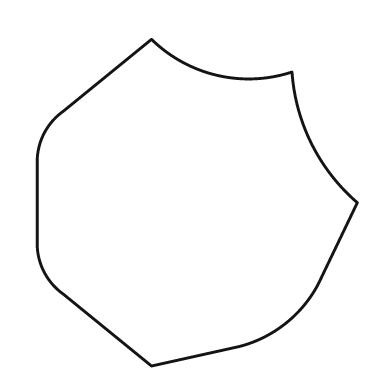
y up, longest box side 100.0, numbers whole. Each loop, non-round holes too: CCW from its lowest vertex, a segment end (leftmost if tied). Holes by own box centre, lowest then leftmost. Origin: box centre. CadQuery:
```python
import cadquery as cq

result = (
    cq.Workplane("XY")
    .moveTo(-14.0, -50.0)
    .lineTo(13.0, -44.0)
    .threePointArc((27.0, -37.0), (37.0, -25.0))
    .lineTo(49.0, 0.0)
    .threePointArc((35.0, 18.0), (29.0, 40.0))
    .threePointArc((6.0, 39.0), (-14.0, 50.0))
    .lineTo(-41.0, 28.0)
    .threePointArc((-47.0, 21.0), (-49.0, 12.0))
    .lineTo(-49.0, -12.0)
    .threePointArc((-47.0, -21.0), (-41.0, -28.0))
    .close()
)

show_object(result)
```